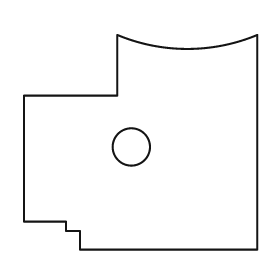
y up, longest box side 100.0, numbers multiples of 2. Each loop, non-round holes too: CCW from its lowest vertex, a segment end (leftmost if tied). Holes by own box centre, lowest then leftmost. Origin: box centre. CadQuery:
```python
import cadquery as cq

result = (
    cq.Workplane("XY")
    .moveTo(-26.0, -46.0)
    .lineTo(50.0, -46.0)
    .lineTo(50.0, 46.0)
    .threePointArc((20.0, 40.0), (-10.0, 46.0))
    .lineTo(-10.0, 20.0)
    .lineTo(-50.0, 20.0)
    .lineTo(-50.0, -34.0)
    .lineTo(-32.0, -34.0)
    .lineTo(-32.0, -38.0)
    .lineTo(-26.0, -38.0)
    .close()
    .moveTo(-4.0, -2.0)
    .circle(8.0)
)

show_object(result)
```